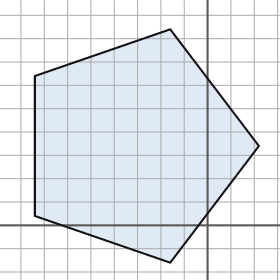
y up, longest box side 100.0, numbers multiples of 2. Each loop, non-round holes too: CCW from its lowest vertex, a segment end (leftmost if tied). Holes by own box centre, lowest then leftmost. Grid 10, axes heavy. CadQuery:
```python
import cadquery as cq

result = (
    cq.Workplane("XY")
    .moveTo(-16.0, -16.0)
    .lineTo(22.0, 34.0)
    .lineTo(-16.0, 84.0)
    .lineTo(-74.0, 64.0)
    .lineTo(-74.0, 4.0)
    .close()
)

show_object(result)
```